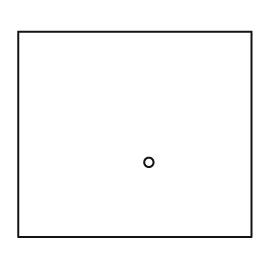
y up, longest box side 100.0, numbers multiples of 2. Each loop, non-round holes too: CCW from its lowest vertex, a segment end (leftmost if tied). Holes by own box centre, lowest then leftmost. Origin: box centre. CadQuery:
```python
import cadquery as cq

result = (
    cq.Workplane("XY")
    .moveTo(-50.0, -44.0)
    .lineTo(50.0, -44.0)
    .lineTo(50.0, 44.0)
    .lineTo(-50.0, 44.0)
    .close()
    .moveTo(6.0, -12.0)
    .circle(2.0)
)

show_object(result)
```